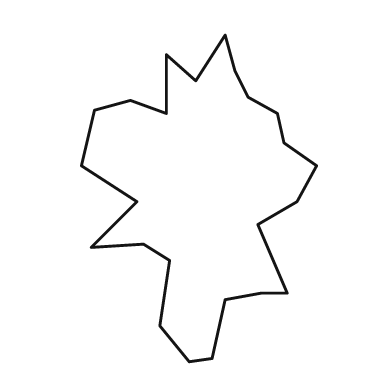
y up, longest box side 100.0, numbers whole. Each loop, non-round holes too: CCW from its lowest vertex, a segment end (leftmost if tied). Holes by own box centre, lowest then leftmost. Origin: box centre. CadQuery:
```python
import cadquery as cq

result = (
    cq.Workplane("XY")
    .moveTo(-3.0, -50.0)
    .lineTo(4.0, -49.0)
    .lineTo(8.0, -31.0)
    .lineTo(19.0, -29.0)
    .lineTo(27.0, -29.0)
    .lineTo(18.0, -8.0)
    .lineTo(30.0, -1.0)
    .lineTo(36.0, 10.0)
    .lineTo(26.0, 17.0)
    .lineTo(24.0, 26.0)
    .lineTo(15.0, 31.0)
    .lineTo(11.0, 39.0)
    .lineTo(8.0, 50.0)
    .lineTo(-1.0, 36.0)
    .lineTo(-10.0, 44.0)
    .lineTo(-10.0, 26.0)
    .lineTo(-21.0, 30.0)
    .lineTo(-32.0, 27.0)
    .lineTo(-36.0, 10.0)
    .lineTo(-19.0, -1.0)
    .lineTo(-33.0, -15.0)
    .lineTo(-17.0, -14.0)
    .lineTo(-9.0, -19.0)
    .lineTo(-12.0, -39.0)
    .close()
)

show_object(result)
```